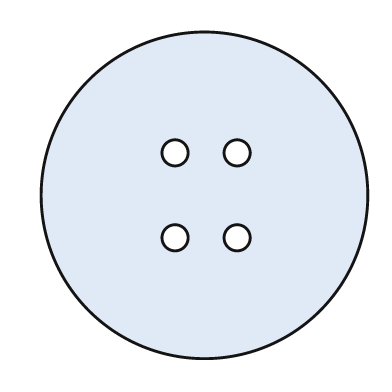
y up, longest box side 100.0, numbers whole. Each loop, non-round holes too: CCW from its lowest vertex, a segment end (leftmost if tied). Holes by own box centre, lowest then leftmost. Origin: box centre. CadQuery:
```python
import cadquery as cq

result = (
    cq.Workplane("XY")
    .moveTo(0.0, 0.0)
    .circle(50.0)
    .moveTo(-9.0, -13.0)
    .circle(4.0)
    .moveTo(10.0, -13.0)
    .circle(4.0)
    .moveTo(-9.0, 13.0)
    .circle(4.0)
    .moveTo(10.0, 13.0)
    .circle(4.0)
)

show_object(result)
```